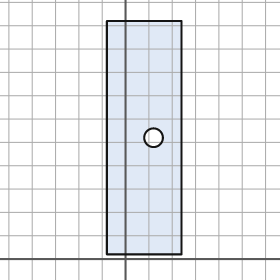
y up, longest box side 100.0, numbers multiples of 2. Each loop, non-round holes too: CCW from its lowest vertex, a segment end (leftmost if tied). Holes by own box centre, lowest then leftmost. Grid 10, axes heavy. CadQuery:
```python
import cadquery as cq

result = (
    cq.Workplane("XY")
    .moveTo(-8.0, 2.0)
    .lineTo(24.0, 2.0)
    .lineTo(24.0, 102.0)
    .lineTo(-8.0, 102.0)
    .close()
    .moveTo(12.0, 52.0)
    .circle(4.0)
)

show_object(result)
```